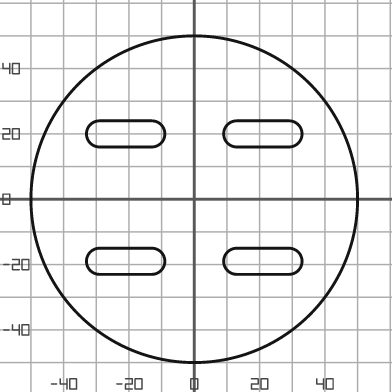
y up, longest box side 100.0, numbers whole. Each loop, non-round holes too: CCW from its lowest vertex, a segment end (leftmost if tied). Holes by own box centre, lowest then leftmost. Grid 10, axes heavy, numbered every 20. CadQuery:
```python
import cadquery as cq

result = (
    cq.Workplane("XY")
    .moveTo(0.0, 0.0)
    .circle(50.0)
    .moveTo(-29.0, -23.0)
    .lineTo(-13.0, -23.0)
    .threePointArc((-9.0, -19.0), (-13.0, -15.0))
    .lineTo(-29.0, -15.0)
    .threePointArc((-33.0, -19.0), (-29.0, -23.0))
    .close()
    .moveTo(13.0, -23.0)
    .lineTo(29.0, -23.0)
    .threePointArc((33.0, -19.0), (29.0, -15.0))
    .lineTo(13.0, -15.0)
    .threePointArc((9.0, -19.0), (13.0, -23.0))
    .close()
    .moveTo(-29.0, 16.0)
    .lineTo(-13.0, 16.0)
    .threePointArc((-9.0, 20.0), (-13.0, 24.0))
    .lineTo(-29.0, 24.0)
    .threePointArc((-33.0, 20.0), (-29.0, 16.0))
    .close()
    .moveTo(13.0, 16.0)
    .lineTo(29.0, 16.0)
    .threePointArc((33.0, 20.0), (29.0, 24.0))
    .lineTo(13.0, 24.0)
    .threePointArc((9.0, 20.0), (13.0, 16.0))
    .close()
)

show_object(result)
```